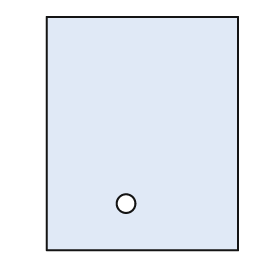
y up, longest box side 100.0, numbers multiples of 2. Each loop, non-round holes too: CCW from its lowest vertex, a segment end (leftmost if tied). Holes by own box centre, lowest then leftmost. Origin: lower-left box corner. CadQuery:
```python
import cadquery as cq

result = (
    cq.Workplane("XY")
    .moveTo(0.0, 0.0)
    .lineTo(82.0, 0.0)
    .lineTo(82.0, 100.0)
    .lineTo(0.0, 100.0)
    .close()
    .moveTo(34.0, 20.0)
    .circle(4.0)
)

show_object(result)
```